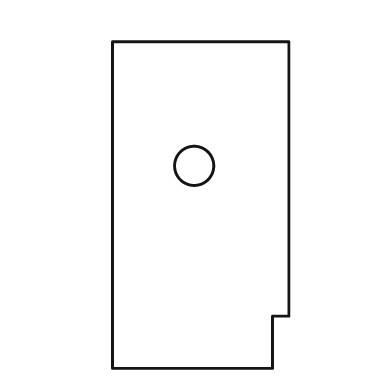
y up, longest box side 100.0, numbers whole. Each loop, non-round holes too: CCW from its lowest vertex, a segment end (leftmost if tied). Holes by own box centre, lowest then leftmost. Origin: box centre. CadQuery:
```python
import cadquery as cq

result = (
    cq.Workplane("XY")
    .moveTo(-27.0, -50.0)
    .lineTo(22.0, -50.0)
    .lineTo(22.0, -34.0)
    .lineTo(27.0, -34.0)
    .lineTo(27.0, 50.0)
    .lineTo(-27.0, 50.0)
    .close()
    .moveTo(-2.0, 12.0)
    .circle(6.0)
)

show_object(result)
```